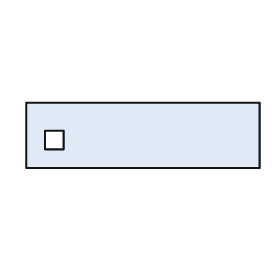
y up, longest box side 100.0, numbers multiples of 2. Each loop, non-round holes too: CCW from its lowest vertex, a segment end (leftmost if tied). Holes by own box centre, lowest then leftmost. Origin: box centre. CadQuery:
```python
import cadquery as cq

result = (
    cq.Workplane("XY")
    .moveTo(-50.0, -14.0)
    .lineTo(50.0, -14.0)
    .lineTo(50.0, 14.0)
    .lineTo(-50.0, 14.0)
    .close()
    .moveTo(-42.0, -6.0)
    .lineTo(-34.0, -6.0)
    .lineTo(-34.0, 2.0)
    .lineTo(-42.0, 2.0)
    .close()
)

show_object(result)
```